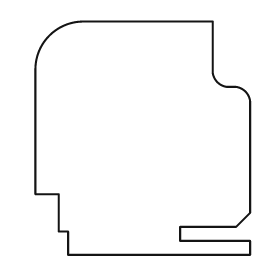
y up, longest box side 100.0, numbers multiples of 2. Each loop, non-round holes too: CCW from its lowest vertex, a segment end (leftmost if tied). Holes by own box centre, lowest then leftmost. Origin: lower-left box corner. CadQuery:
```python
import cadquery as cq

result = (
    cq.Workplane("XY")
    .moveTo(14.0, 0.0)
    .lineTo(92.0, 0.0)
    .lineTo(92.0, 6.0)
    .lineTo(62.0, 6.0)
    .lineTo(62.0, 12.0)
    .lineTo(86.0, 12.0)
    .lineTo(92.0, 18.0)
    .lineTo(92.0, 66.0)
    .threePointArc((90.0, 70.0), (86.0, 72.0))
    .lineTo(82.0, 72.0)
    .threePointArc((78.0, 74.0), (76.0, 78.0))
    .lineTo(76.0, 100.0)
    .lineTo(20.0, 100.0)
    .threePointArc((6.0, 94.0), (0.0, 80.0))
    .lineTo(0.0, 26.0)
    .lineTo(10.0, 26.0)
    .lineTo(10.0, 10.0)
    .lineTo(14.0, 10.0)
    .close()
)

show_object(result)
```